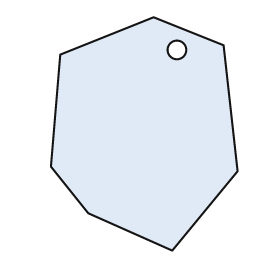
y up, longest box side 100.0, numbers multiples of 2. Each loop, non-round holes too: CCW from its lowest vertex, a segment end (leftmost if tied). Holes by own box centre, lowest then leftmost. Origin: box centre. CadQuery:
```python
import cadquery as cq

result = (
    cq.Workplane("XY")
    .moveTo(12.0, -50.0)
    .lineTo(40.0, -16.0)
    .lineTo(34.0, 38.0)
    .lineTo(4.0, 50.0)
    .lineTo(-36.0, 34.0)
    .lineTo(-40.0, -14.0)
    .lineTo(-24.0, -34.0)
    .close()
    .moveTo(14.0, 36.0)
    .circle(4.0)
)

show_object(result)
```